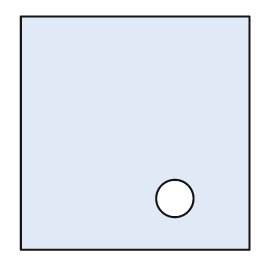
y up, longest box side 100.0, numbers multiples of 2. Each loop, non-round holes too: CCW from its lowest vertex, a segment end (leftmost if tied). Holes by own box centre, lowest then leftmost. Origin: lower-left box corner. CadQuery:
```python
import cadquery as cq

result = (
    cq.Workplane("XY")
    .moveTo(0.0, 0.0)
    .lineTo(98.0, 0.0)
    .lineTo(98.0, 100.0)
    .lineTo(0.0, 100.0)
    .close()
    .moveTo(66.0, 22.0)
    .circle(8.0)
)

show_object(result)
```